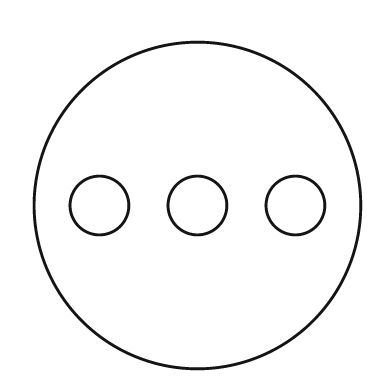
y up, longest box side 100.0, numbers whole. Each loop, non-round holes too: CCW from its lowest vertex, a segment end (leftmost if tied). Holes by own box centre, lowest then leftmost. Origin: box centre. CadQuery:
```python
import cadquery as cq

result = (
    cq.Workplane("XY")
    .moveTo(0.0, 0.0)
    .circle(50.0)
    .moveTo(-30.0, 0.0)
    .circle(9.0)
    .moveTo(0.0, 0.0)
    .circle(9.0)
    .moveTo(30.0, 0.0)
    .circle(9.0)
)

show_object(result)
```